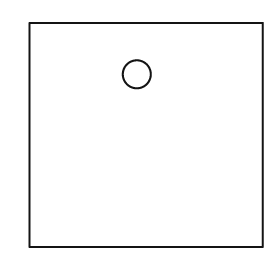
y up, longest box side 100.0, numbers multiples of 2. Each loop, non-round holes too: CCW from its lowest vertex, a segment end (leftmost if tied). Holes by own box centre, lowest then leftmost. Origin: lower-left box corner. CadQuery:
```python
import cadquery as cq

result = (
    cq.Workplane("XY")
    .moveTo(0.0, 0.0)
    .lineTo(100.0, 0.0)
    .lineTo(100.0, 96.0)
    .lineTo(0.0, 96.0)
    .close()
    .moveTo(46.0, 74.0)
    .circle(6.0)
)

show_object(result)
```